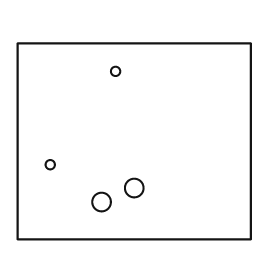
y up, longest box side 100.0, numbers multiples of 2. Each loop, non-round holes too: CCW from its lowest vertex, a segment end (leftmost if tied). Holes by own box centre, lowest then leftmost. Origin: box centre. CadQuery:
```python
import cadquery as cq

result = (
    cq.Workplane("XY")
    .moveTo(-50.0, -42.0)
    .lineTo(50.0, -42.0)
    .lineTo(50.0, 42.0)
    .lineTo(-50.0, 42.0)
    .close()
    .moveTo(-14.0, -26.0)
    .circle(4.0)
    .moveTo(0.0, -20.0)
    .circle(4.0)
    .moveTo(-36.0, -10.0)
    .circle(2.0)
    .moveTo(-8.0, 30.0)
    .circle(2.0)
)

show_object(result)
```